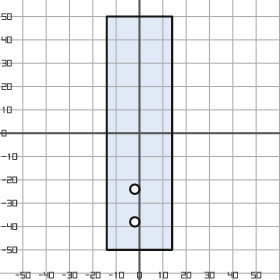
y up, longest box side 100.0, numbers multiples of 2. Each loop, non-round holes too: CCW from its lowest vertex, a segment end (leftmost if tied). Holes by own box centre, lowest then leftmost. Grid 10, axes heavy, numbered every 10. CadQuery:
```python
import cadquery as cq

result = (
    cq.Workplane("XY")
    .moveTo(-14.0, -50.0)
    .lineTo(14.0, -50.0)
    .lineTo(14.0, 50.0)
    .lineTo(-14.0, 50.0)
    .close()
    .moveTo(-2.0, -38.0)
    .circle(2.0)
    .moveTo(-2.0, -24.0)
    .circle(2.0)
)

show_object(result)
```